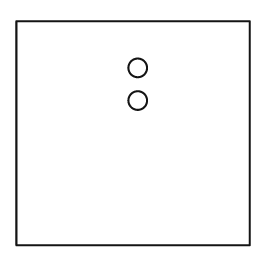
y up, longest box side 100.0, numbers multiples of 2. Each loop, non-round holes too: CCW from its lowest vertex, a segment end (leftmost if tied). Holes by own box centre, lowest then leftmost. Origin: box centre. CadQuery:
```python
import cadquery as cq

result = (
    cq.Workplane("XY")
    .moveTo(-50.0, -48.0)
    .lineTo(50.0, -48.0)
    .lineTo(50.0, 48.0)
    .lineTo(-50.0, 48.0)
    .close()
    .moveTo(2.0, 14.0)
    .circle(4.0)
    .moveTo(2.0, 28.0)
    .circle(4.0)
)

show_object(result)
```